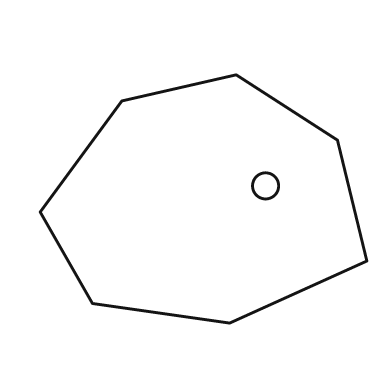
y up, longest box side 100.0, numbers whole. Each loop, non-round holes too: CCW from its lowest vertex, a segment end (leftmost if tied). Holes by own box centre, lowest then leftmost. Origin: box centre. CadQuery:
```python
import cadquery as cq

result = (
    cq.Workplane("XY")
    .moveTo(8.0, -38.0)
    .lineTo(50.0, -19.0)
    .lineTo(41.0, 18.0)
    .lineTo(10.0, 38.0)
    .lineTo(-25.0, 30.0)
    .lineTo(-50.0, -4.0)
    .lineTo(-34.0, -32.0)
    .close()
    .moveTo(19.0, 4.0)
    .circle(4.0)
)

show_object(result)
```